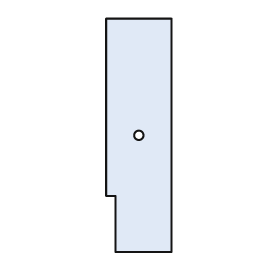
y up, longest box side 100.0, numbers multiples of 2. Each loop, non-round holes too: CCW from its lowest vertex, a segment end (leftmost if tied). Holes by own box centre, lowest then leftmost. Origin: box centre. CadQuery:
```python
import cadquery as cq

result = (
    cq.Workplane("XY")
    .moveTo(-10.0, -50.0)
    .lineTo(14.0, -50.0)
    .lineTo(14.0, 50.0)
    .lineTo(-14.0, 50.0)
    .lineTo(-14.0, -26.0)
    .lineTo(-10.0, -26.0)
    .close()
    .moveTo(0.0, 0.0)
    .circle(2.0)
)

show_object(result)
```